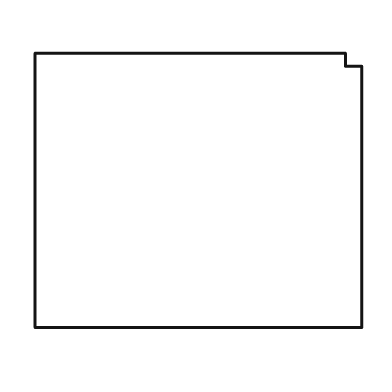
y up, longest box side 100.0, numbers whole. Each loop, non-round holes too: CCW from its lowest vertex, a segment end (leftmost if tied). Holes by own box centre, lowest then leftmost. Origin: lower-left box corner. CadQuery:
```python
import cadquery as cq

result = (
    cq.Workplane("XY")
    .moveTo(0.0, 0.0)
    .lineTo(100.0, 0.0)
    .lineTo(100.0, 80.0)
    .lineTo(95.0, 80.0)
    .lineTo(95.0, 84.0)
    .lineTo(0.0, 84.0)
    .close()
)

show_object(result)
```